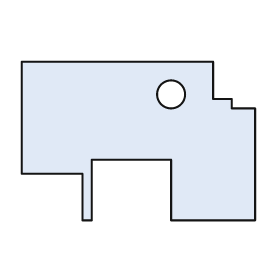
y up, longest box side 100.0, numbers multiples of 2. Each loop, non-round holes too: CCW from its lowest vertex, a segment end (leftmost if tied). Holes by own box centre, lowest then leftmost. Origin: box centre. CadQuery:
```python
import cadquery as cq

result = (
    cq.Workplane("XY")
    .moveTo(-24.0, -34.0)
    .lineTo(-20.0, -34.0)
    .lineTo(-20.0, -8.0)
    .lineTo(14.0, -8.0)
    .lineTo(14.0, -34.0)
    .lineTo(50.0, -34.0)
    .lineTo(50.0, 14.0)
    .lineTo(40.0, 14.0)
    .lineTo(40.0, 18.0)
    .lineTo(32.0, 18.0)
    .lineTo(32.0, 34.0)
    .lineTo(-50.0, 34.0)
    .lineTo(-50.0, -14.0)
    .lineTo(-24.0, -14.0)
    .close()
    .moveTo(14.0, 20.0)
    .circle(6.0)
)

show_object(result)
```